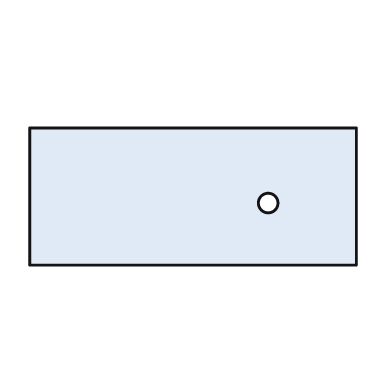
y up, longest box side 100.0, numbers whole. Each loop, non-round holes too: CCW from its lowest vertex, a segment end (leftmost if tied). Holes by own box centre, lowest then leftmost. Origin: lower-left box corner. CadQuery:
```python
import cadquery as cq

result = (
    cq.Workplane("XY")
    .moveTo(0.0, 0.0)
    .lineTo(100.0, 0.0)
    .lineTo(100.0, 42.0)
    .lineTo(0.0, 42.0)
    .close()
    .moveTo(73.0, 19.0)
    .circle(3.0)
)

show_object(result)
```